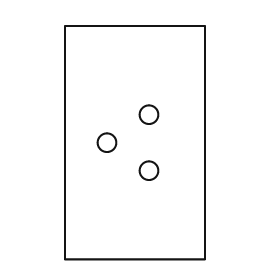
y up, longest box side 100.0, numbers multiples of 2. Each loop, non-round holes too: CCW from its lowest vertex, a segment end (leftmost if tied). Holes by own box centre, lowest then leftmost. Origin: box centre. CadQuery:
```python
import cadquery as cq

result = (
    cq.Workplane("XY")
    .moveTo(-30.0, -50.0)
    .lineTo(30.0, -50.0)
    .lineTo(30.0, 50.0)
    .lineTo(-30.0, 50.0)
    .close()
    .moveTo(6.0, -12.0)
    .circle(4.0)
    .moveTo(-12.0, 0.0)
    .circle(4.0)
    .moveTo(6.0, 12.0)
    .circle(4.0)
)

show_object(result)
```